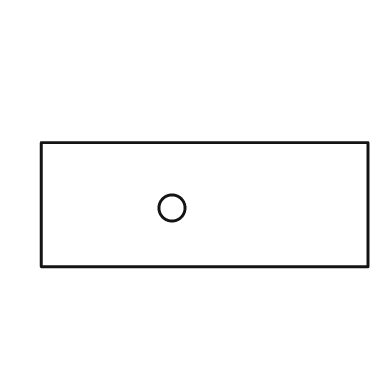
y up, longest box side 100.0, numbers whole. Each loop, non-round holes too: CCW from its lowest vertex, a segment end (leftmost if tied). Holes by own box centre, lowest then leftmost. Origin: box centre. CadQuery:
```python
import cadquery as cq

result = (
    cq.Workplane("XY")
    .moveTo(-50.0, -19.0)
    .lineTo(50.0, -19.0)
    .lineTo(50.0, 19.0)
    .lineTo(-50.0, 19.0)
    .close()
    .moveTo(-10.0, -1.0)
    .circle(4.0)
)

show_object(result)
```